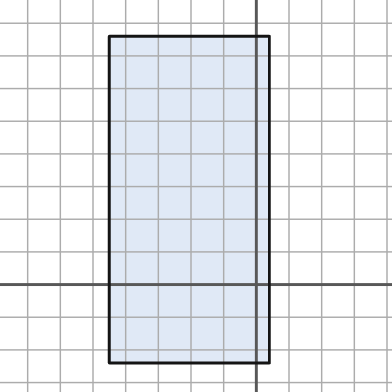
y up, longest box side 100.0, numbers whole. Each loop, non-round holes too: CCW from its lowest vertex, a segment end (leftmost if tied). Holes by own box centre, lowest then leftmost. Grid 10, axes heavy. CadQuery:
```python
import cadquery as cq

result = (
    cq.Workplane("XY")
    .moveTo(-45.0, -24.0)
    .lineTo(4.0, -24.0)
    .lineTo(4.0, 76.0)
    .lineTo(-45.0, 76.0)
    .close()
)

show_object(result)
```